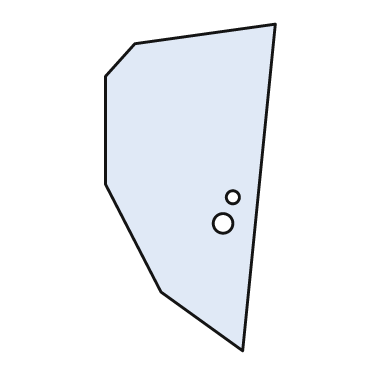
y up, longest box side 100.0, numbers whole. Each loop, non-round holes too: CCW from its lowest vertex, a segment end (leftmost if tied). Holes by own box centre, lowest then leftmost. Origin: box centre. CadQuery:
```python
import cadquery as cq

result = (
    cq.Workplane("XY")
    .moveTo(16.0, -50.0)
    .lineTo(26.0, 50.0)
    .lineTo(-17.0, 44.0)
    .lineTo(-26.0, 34.0)
    .lineTo(-26.0, 1.0)
    .lineTo(-9.0, -32.0)
    .close()
    .moveTo(10.0, -11.0)
    .circle(3.0)
    .moveTo(13.0, -3.0)
    .circle(2.0)
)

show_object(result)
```